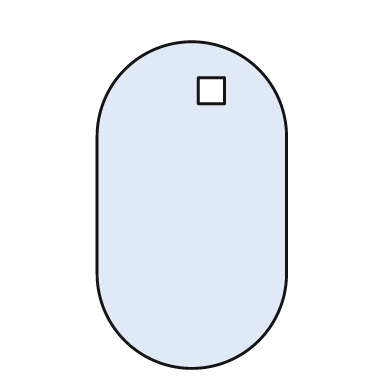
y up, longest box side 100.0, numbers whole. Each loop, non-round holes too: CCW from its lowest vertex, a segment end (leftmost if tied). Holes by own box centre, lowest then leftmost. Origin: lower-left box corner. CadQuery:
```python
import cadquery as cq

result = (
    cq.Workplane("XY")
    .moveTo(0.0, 29.0)
    .threePointArc((29.0, 0.0), (58.0, 29.0))
    .lineTo(58.0, 71.0)
    .threePointArc((29.0, 100.0), (0.0, 71.0))
    .close()
    .moveTo(31.0, 81.0)
    .lineTo(39.0, 81.0)
    .lineTo(39.0, 89.0)
    .lineTo(31.0, 89.0)
    .close()
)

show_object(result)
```